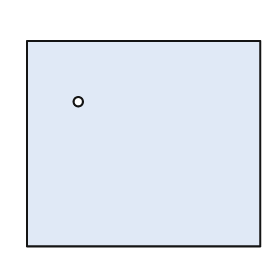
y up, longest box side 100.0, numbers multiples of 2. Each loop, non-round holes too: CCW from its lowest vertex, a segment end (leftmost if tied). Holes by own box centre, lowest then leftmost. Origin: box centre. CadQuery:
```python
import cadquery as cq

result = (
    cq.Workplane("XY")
    .moveTo(-50.0, -44.0)
    .lineTo(50.0, -44.0)
    .lineTo(50.0, 44.0)
    .lineTo(-50.0, 44.0)
    .close()
    .moveTo(-28.0, 18.0)
    .circle(2.0)
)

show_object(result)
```